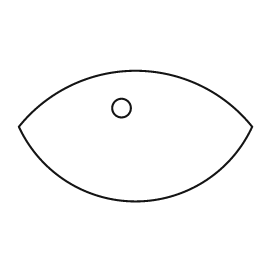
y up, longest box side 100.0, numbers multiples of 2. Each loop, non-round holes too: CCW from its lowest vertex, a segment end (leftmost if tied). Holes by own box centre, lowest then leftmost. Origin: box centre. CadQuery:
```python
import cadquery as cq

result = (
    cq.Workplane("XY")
    .moveTo(-50.0, 4.0)
    .threePointArc((0.0, -28.0), (50.0, 4.0))
    .threePointArc((0.0, 28.0), (-50.0, 4.0))
    .close()
    .moveTo(-6.0, 12.0)
    .circle(4.0)
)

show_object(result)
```